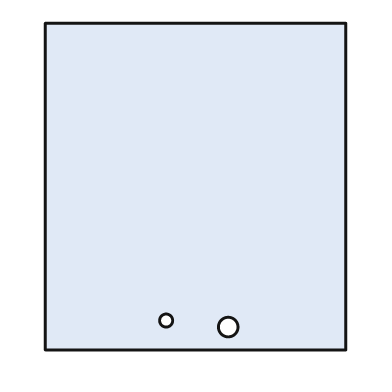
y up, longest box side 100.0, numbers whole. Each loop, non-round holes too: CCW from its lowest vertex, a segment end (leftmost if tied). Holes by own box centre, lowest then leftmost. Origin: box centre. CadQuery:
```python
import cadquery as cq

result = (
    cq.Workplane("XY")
    .moveTo(-46.0, -50.0)
    .lineTo(46.0, -50.0)
    .lineTo(46.0, 50.0)
    .lineTo(-46.0, 50.0)
    .close()
    .moveTo(10.0, -43.0)
    .circle(3.0)
    .moveTo(-9.0, -41.0)
    .circle(2.0)
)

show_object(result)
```